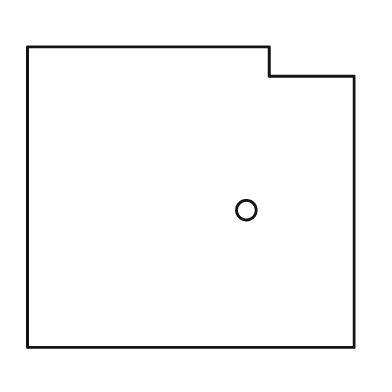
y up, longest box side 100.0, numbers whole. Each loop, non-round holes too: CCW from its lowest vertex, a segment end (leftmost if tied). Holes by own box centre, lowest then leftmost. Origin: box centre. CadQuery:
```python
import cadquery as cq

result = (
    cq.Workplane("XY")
    .moveTo(-50.0, -46.0)
    .lineTo(50.0, -46.0)
    .lineTo(50.0, 37.0)
    .lineTo(24.0, 37.0)
    .lineTo(24.0, 46.0)
    .lineTo(-50.0, 46.0)
    .close()
    .moveTo(17.0, -4.0)
    .circle(3.0)
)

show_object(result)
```